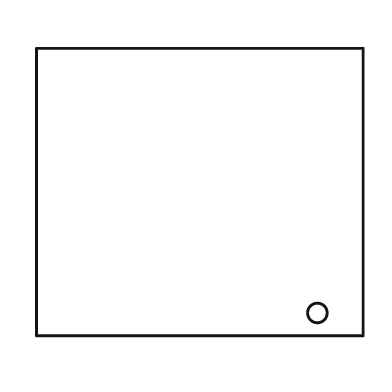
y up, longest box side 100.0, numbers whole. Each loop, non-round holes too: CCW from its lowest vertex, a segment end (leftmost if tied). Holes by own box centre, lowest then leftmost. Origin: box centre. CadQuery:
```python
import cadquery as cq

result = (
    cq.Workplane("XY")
    .moveTo(-50.0, -44.0)
    .lineTo(50.0, -44.0)
    .lineTo(50.0, 44.0)
    .lineTo(-50.0, 44.0)
    .close()
    .moveTo(36.0, -37.0)
    .circle(3.0)
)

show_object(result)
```